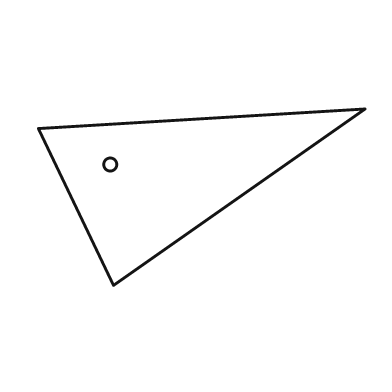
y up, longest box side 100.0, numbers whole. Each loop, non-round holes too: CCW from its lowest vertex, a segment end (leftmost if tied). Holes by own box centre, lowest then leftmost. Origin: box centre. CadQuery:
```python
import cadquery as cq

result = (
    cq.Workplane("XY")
    .moveTo(-27.0, -27.0)
    .lineTo(50.0, 27.0)
    .lineTo(-50.0, 21.0)
    .close()
    .moveTo(-28.0, 10.0)
    .circle(2.0)
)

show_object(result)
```